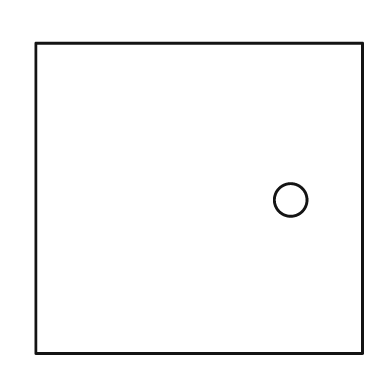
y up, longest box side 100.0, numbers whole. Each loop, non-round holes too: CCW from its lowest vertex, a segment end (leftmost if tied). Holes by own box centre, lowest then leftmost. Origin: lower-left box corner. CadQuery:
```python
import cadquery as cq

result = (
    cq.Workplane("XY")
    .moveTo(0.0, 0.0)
    .lineTo(100.0, 0.0)
    .lineTo(100.0, 95.0)
    .lineTo(0.0, 95.0)
    .close()
    .moveTo(78.0, 47.0)
    .circle(5.0)
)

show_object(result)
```